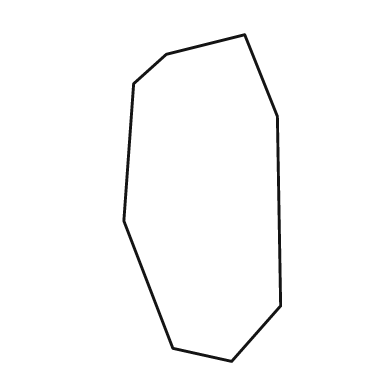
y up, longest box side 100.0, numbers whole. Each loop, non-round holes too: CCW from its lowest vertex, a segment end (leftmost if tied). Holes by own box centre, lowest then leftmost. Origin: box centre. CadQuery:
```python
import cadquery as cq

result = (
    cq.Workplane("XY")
    .moveTo(9.0, -50.0)
    .lineTo(24.0, -33.0)
    .lineTo(23.0, 25.0)
    .lineTo(13.0, 50.0)
    .lineTo(-11.0, 44.0)
    .lineTo(-21.0, 35.0)
    .lineTo(-24.0, -7.0)
    .lineTo(-9.0, -46.0)
    .close()
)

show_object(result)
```